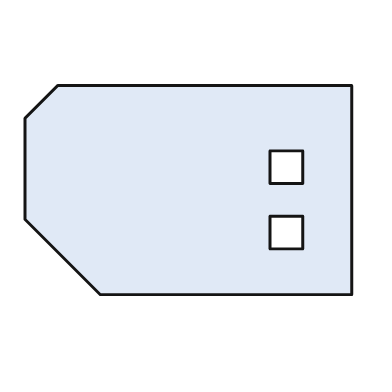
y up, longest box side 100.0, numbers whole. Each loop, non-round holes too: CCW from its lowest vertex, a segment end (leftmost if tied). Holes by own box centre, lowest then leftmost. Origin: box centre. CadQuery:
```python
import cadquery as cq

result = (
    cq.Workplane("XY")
    .moveTo(-27.0, -32.0)
    .lineTo(50.0, -32.0)
    .lineTo(50.0, 32.0)
    .lineTo(-40.0, 32.0)
    .lineTo(-50.0, 22.0)
    .lineTo(-50.0, -9.0)
    .close()
    .moveTo(25.0, -18.0)
    .lineTo(35.0, -18.0)
    .lineTo(35.0, -8.0)
    .lineTo(25.0, -8.0)
    .close()
    .moveTo(25.0, 2.0)
    .lineTo(35.0, 2.0)
    .lineTo(35.0, 12.0)
    .lineTo(25.0, 12.0)
    .close()
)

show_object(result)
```